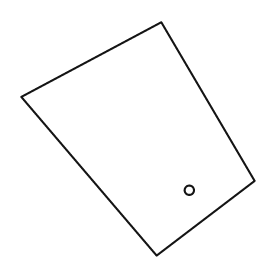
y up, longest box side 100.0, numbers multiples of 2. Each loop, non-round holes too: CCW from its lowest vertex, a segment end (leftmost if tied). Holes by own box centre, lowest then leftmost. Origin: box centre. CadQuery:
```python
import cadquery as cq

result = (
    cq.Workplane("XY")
    .moveTo(8.0, -50.0)
    .lineTo(50.0, -18.0)
    .lineTo(10.0, 50.0)
    .lineTo(-50.0, 18.0)
    .close()
    .moveTo(22.0, -22.0)
    .circle(2.0)
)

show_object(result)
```